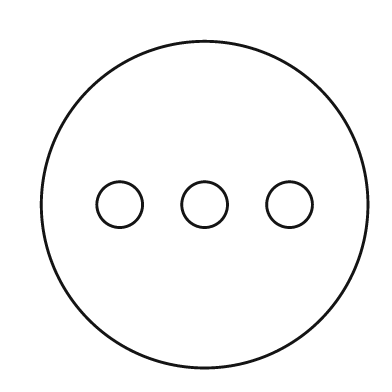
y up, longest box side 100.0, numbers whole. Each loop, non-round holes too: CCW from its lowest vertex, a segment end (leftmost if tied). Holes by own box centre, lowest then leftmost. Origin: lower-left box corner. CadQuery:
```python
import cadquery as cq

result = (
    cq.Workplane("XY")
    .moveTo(50.0, 50.0)
    .circle(50.0)
    .moveTo(24.0, 50.0)
    .circle(7.0)
    .moveTo(50.0, 50.0)
    .circle(7.0)
    .moveTo(76.0, 50.0)
    .circle(7.0)
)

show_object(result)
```